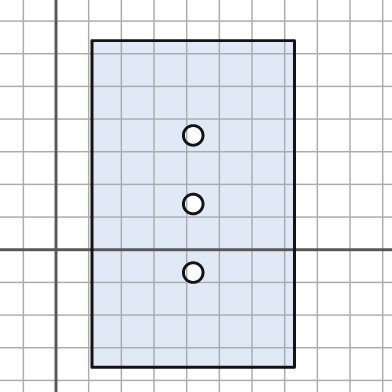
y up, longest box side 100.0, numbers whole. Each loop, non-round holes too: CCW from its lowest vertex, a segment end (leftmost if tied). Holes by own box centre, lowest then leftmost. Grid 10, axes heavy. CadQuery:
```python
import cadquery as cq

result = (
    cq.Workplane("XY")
    .moveTo(11.0, -36.0)
    .lineTo(73.0, -36.0)
    .lineTo(73.0, 64.0)
    .lineTo(11.0, 64.0)
    .close()
    .moveTo(42.0, -7.0)
    .circle(3.0)
    .moveTo(42.0, 14.0)
    .circle(3.0)
    .moveTo(42.0, 35.0)
    .circle(3.0)
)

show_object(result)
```